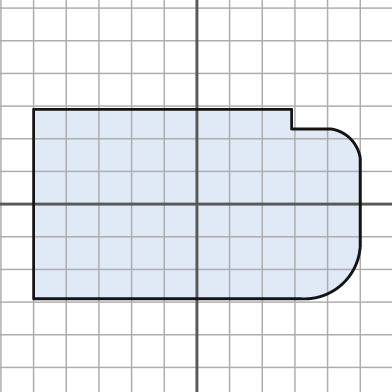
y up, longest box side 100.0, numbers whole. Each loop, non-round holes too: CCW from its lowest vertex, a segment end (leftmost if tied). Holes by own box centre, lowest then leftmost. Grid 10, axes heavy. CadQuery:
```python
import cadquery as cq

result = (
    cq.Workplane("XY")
    .moveTo(-50.0, -29.0)
    .lineTo(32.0, -29.0)
    .threePointArc((45.0, -24.0), (50.0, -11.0))
    .lineTo(50.0, 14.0)
    .threePointArc((47.0, 20.0), (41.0, 23.0))
    .lineTo(29.0, 23.0)
    .lineTo(29.0, 29.0)
    .lineTo(-50.0, 29.0)
    .close()
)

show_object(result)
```